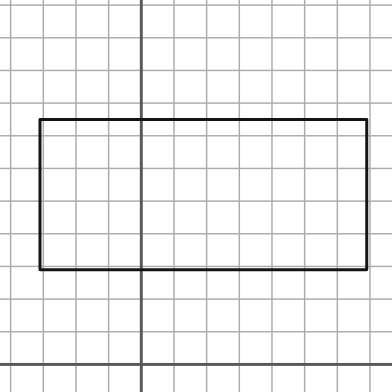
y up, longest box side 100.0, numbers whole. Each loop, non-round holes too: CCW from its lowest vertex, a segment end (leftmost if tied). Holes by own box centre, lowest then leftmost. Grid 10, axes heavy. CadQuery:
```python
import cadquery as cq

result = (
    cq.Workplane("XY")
    .moveTo(-31.0, 29.0)
    .lineTo(69.0, 29.0)
    .lineTo(69.0, 75.0)
    .lineTo(-31.0, 75.0)
    .close()
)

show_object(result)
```